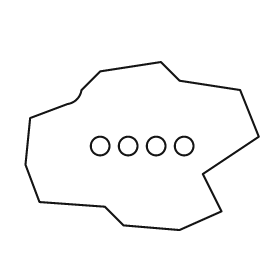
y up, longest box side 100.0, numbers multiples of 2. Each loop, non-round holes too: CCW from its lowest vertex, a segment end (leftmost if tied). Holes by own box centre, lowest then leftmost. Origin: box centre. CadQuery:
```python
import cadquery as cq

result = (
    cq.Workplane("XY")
    .moveTo(16.0, -36.0)
    .lineTo(34.0, -28.0)
    .lineTo(26.0, -12.0)
    .lineTo(50.0, 4.0)
    .lineTo(42.0, 24.0)
    .lineTo(16.0, 28.0)
    .lineTo(8.0, 36.0)
    .lineTo(-18.0, 32.0)
    .lineTo(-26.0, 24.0)
    .threePointArc((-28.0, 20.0), (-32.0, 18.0))
    .lineTo(-48.0, 12.0)
    .lineTo(-50.0, -8.0)
    .lineTo(-44.0, -24.0)
    .lineTo(-16.0, -26.0)
    .lineTo(-8.0, -34.0)
    .close()
    .moveTo(-18.0, 0.0)
    .circle(4.0)
    .moveTo(-6.0, 0.0)
    .circle(4.0)
    .moveTo(6.0, 0.0)
    .circle(4.0)
    .moveTo(18.0, 0.0)
    .circle(4.0)
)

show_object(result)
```